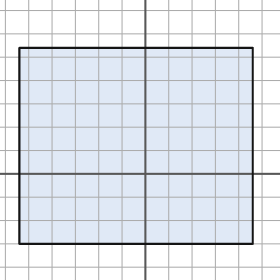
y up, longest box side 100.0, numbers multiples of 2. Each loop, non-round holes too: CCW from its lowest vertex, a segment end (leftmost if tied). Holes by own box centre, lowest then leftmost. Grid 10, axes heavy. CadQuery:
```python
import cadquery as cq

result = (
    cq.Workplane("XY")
    .moveTo(-54.0, -30.0)
    .lineTo(46.0, -30.0)
    .lineTo(46.0, 54.0)
    .lineTo(-54.0, 54.0)
    .close()
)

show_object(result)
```